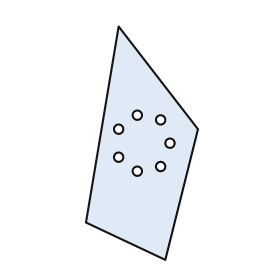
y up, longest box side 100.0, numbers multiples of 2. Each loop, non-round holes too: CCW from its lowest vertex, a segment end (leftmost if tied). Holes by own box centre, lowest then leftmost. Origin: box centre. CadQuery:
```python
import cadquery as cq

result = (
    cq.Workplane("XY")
    .moveTo(10.0, -50.0)
    .lineTo(24.0, 6.0)
    .lineTo(-10.0, 50.0)
    .lineTo(-24.0, -34.0)
    .close()
    .moveTo(-2.0, -12.0)
    .circle(2.0)
    .moveTo(8.0, -10.0)
    .circle(2.0)
    .moveTo(-10.0, -6.0)
    .circle(2.0)
    .moveTo(12.0, 0.0)
    .circle(2.0)
    .moveTo(-10.0, 6.0)
    .circle(2.0)
    .moveTo(8.0, 10.0)
    .circle(2.0)
    .moveTo(-2.0, 12.0)
    .circle(2.0)
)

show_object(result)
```